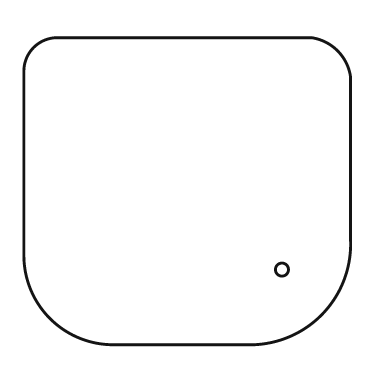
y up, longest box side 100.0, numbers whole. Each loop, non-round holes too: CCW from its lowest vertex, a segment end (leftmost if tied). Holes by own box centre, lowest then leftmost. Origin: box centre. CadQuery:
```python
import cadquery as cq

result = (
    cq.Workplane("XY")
    .moveTo(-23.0, -47.0)
    .lineTo(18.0, -47.0)
    .threePointArc((41.0, -38.0), (50.0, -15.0))
    .lineTo(50.0, 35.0)
    .threePointArc((46.0, 43.0), (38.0, 47.0))
    .lineTo(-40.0, 47.0)
    .threePointArc((-47.0, 44.0), (-50.0, 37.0))
    .lineTo(-50.0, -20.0)
    .threePointArc((-42.0, -39.0), (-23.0, -47.0))
    .close()
    .moveTo(29.0, -24.0)
    .circle(2.0)
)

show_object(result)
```